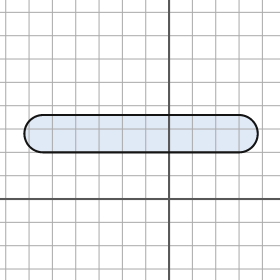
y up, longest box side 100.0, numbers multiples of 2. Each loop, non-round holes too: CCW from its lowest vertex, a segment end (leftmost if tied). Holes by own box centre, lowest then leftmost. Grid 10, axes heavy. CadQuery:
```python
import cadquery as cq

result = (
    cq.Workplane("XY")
    .moveTo(-54.0, 20.0)
    .lineTo(30.0, 20.0)
    .threePointArc((38.0, 28.0), (30.0, 36.0))
    .lineTo(-54.0, 36.0)
    .threePointArc((-62.0, 28.0), (-54.0, 20.0))
    .close()
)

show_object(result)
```